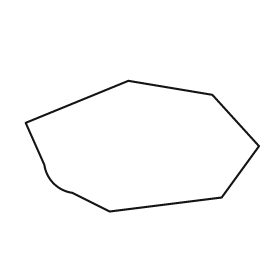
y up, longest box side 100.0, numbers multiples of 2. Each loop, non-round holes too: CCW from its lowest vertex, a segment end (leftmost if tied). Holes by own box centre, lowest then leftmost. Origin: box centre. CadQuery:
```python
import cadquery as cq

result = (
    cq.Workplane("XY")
    .moveTo(-14.0, -28.0)
    .lineTo(34.0, -22.0)
    .lineTo(50.0, 0.0)
    .lineTo(30.0, 22.0)
    .lineTo(-6.0, 28.0)
    .lineTo(-50.0, 10.0)
    .lineTo(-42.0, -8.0)
    .threePointArc((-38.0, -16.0), (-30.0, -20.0))
    .close()
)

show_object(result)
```